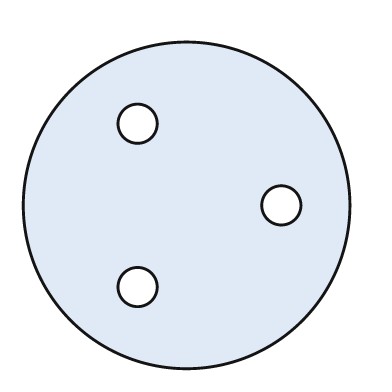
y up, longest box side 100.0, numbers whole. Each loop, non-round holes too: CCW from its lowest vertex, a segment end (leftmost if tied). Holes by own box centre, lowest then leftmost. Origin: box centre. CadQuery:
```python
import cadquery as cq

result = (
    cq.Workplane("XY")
    .moveTo(0.0, 0.0)
    .circle(50.0)
    .moveTo(-15.0, -25.0)
    .circle(6.0)
    .moveTo(29.0, 0.0)
    .circle(6.0)
    .moveTo(-15.0, 25.0)
    .circle(6.0)
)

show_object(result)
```